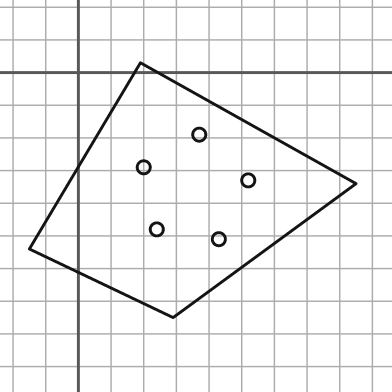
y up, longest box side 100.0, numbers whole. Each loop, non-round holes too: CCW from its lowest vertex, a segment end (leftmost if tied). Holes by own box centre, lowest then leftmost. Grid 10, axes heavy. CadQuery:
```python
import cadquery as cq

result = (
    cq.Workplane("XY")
    .moveTo(29.0, -75.0)
    .lineTo(85.0, -34.0)
    .lineTo(19.0, 3.0)
    .lineTo(-15.0, -54.0)
    .close()
    .moveTo(43.0, -51.0)
    .circle(2.0)
    .moveTo(24.0, -48.0)
    .circle(2.0)
    .moveTo(52.0, -33.0)
    .circle(2.0)
    .moveTo(20.0, -29.0)
    .circle(2.0)
    .moveTo(37.0, -19.0)
    .circle(2.0)
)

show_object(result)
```